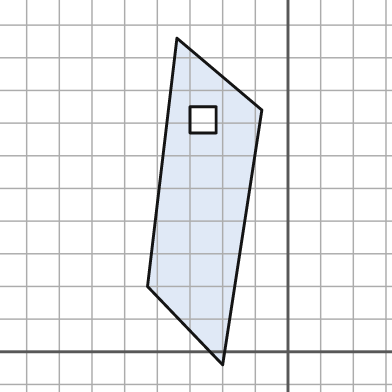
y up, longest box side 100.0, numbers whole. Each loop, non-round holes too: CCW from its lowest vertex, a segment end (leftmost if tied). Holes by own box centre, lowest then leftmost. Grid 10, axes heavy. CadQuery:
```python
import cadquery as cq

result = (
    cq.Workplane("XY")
    .moveTo(-20.0, -4.0)
    .lineTo(-8.0, 74.0)
    .lineTo(-34.0, 96.0)
    .lineTo(-43.0, 20.0)
    .close()
    .moveTo(-30.0, 67.0)
    .lineTo(-22.0, 67.0)
    .lineTo(-22.0, 75.0)
    .lineTo(-30.0, 75.0)
    .close()
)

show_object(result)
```